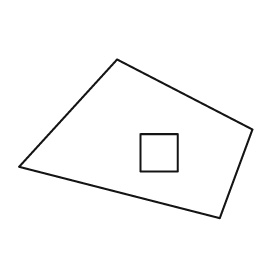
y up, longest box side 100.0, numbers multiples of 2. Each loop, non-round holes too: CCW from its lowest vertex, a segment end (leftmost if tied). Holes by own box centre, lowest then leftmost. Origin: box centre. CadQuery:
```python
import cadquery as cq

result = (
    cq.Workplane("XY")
    .moveTo(36.0, -34.0)
    .lineTo(50.0, 4.0)
    .lineTo(-8.0, 34.0)
    .lineTo(-50.0, -12.0)
    .close()
    .moveTo(2.0, -14.0)
    .lineTo(18.0, -14.0)
    .lineTo(18.0, 2.0)
    .lineTo(2.0, 2.0)
    .close()
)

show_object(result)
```